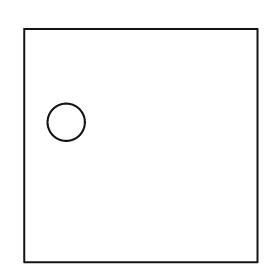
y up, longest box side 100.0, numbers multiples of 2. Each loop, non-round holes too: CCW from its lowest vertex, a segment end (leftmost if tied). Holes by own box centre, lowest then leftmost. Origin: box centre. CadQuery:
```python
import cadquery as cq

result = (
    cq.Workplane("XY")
    .moveTo(-50.0, -50.0)
    .lineTo(50.0, -50.0)
    .lineTo(50.0, 50.0)
    .lineTo(-50.0, 50.0)
    .close()
    .moveTo(-32.0, 10.0)
    .circle(8.0)
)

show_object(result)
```